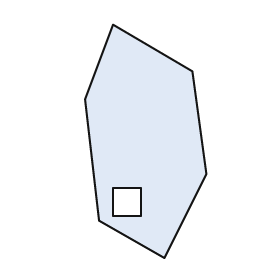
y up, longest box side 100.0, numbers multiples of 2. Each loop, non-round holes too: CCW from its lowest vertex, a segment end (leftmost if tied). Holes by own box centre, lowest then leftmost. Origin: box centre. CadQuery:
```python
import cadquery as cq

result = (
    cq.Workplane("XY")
    .moveTo(8.0, -50.0)
    .lineTo(26.0, -14.0)
    .lineTo(20.0, 30.0)
    .lineTo(-14.0, 50.0)
    .lineTo(-26.0, 18.0)
    .lineTo(-20.0, -34.0)
    .close()
    .moveTo(-14.0, -32.0)
    .lineTo(-2.0, -32.0)
    .lineTo(-2.0, -20.0)
    .lineTo(-14.0, -20.0)
    .close()
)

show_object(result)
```